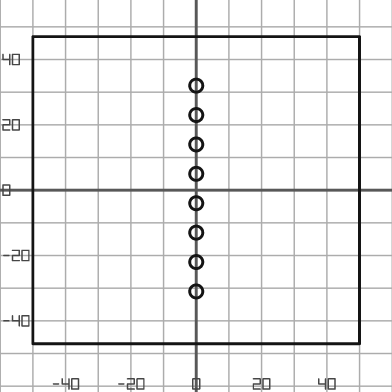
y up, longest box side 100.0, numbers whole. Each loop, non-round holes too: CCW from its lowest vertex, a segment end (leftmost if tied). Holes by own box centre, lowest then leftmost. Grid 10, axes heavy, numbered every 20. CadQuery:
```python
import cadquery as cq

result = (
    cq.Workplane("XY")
    .moveTo(-50.0, -47.0)
    .lineTo(50.0, -47.0)
    .lineTo(50.0, 47.0)
    .lineTo(-50.0, 47.0)
    .close()
    .moveTo(0.0, -31.0)
    .circle(2.0)
    .moveTo(0.0, -22.0)
    .circle(2.0)
    .moveTo(0.0, -13.0)
    .circle(2.0)
    .moveTo(0.0, -4.0)
    .circle(2.0)
    .moveTo(0.0, 5.0)
    .circle(2.0)
    .moveTo(0.0, 14.0)
    .circle(2.0)
    .moveTo(0.0, 23.0)
    .circle(2.0)
    .moveTo(0.0, 32.0)
    .circle(2.0)
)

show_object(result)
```